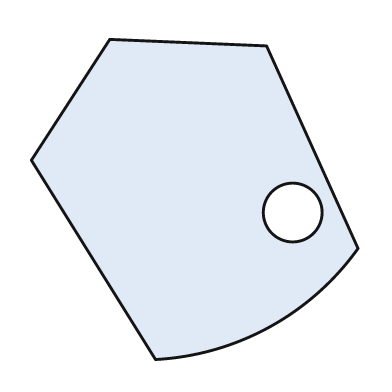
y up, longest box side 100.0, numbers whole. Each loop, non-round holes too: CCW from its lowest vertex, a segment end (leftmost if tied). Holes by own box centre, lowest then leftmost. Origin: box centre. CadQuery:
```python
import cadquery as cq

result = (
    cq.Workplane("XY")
    .moveTo(-12.0, -49.0)
    .threePointArc((23.0, -39.0), (50.0, -15.0))
    .lineTo(22.0, 47.0)
    .lineTo(-26.0, 49.0)
    .lineTo(-50.0, 12.0)
    .close()
    .moveTo(30.0, -4.0)
    .circle(9.0)
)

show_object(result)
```